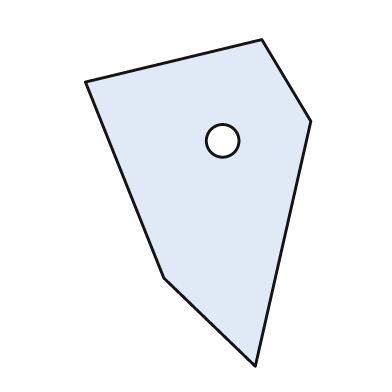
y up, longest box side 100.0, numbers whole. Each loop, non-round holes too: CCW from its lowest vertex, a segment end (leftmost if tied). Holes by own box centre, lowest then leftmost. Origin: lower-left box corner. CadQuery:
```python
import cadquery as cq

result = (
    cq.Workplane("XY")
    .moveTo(52.0, 0.0)
    .lineTo(69.0, 75.0)
    .lineTo(54.0, 100.0)
    .lineTo(0.0, 87.0)
    .lineTo(24.0, 27.0)
    .close()
    .moveTo(42.0, 69.0)
    .circle(5.0)
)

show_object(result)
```